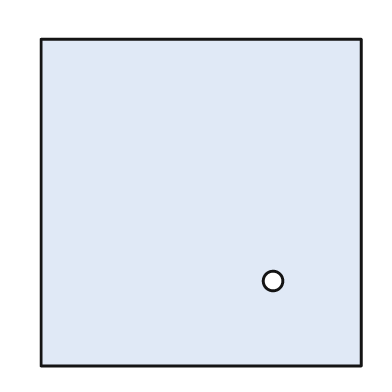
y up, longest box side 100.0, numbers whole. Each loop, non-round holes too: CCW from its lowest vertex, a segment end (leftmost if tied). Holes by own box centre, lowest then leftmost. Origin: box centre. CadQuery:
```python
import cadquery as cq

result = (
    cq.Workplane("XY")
    .moveTo(-49.0, -50.0)
    .lineTo(49.0, -50.0)
    .lineTo(49.0, 50.0)
    .lineTo(-49.0, 50.0)
    .close()
    .moveTo(22.0, -24.0)
    .circle(3.0)
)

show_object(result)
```